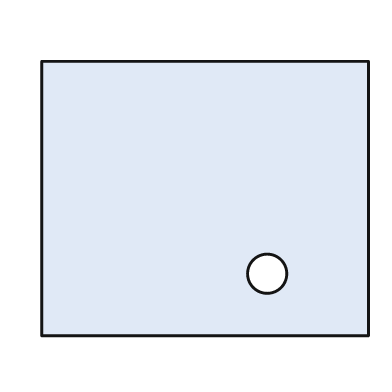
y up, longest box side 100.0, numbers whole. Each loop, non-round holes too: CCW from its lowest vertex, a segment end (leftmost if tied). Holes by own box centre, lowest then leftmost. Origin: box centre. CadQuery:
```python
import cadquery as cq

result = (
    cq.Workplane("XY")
    .moveTo(-50.0, -42.0)
    .lineTo(50.0, -42.0)
    .lineTo(50.0, 42.0)
    .lineTo(-50.0, 42.0)
    .close()
    .moveTo(19.0, -23.0)
    .circle(6.0)
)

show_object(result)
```